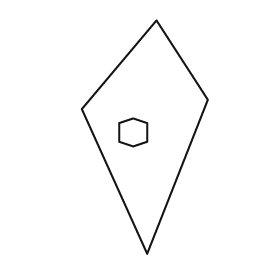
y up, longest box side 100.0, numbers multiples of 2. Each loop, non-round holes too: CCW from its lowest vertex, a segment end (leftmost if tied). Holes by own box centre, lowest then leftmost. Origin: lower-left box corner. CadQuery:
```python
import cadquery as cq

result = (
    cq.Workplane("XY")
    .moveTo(28.0, 0.0)
    .lineTo(54.0, 66.0)
    .lineTo(32.0, 100.0)
    .lineTo(0.0, 62.0)
    .close()
    .moveTo(22.0, 46.0)
    .lineTo(28.0, 48.0)
    .lineTo(28.0, 56.0)
    .lineTo(22.0, 58.0)
    .lineTo(16.0, 56.0)
    .lineTo(16.0, 48.0)
    .close()
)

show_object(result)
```